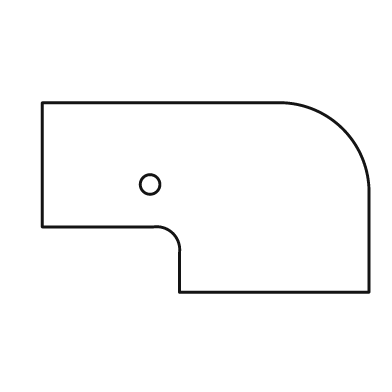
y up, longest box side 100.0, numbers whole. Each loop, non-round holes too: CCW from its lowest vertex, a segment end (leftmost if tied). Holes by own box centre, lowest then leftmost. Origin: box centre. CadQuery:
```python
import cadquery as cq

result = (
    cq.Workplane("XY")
    .moveTo(-8.0, -29.0)
    .lineTo(50.0, -29.0)
    .lineTo(50.0, 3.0)
    .threePointArc((42.0, 21.0), (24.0, 29.0))
    .lineTo(-50.0, 29.0)
    .lineTo(-50.0, -9.0)
    .lineTo(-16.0, -9.0)
    .threePointArc((-10.0, -11.0), (-8.0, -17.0))
    .close()
    .moveTo(-17.0, 4.0)
    .circle(3.0)
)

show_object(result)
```